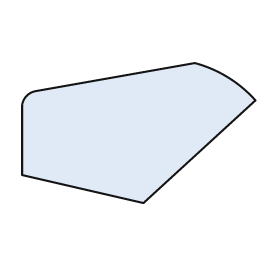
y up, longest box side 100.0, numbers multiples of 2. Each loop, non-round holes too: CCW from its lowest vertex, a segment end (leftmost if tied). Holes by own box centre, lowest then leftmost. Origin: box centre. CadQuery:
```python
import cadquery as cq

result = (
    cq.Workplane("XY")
    .moveTo(2.0, -30.0)
    .lineTo(50.0, 14.0)
    .threePointArc((38.0, 24.0), (24.0, 30.0))
    .lineTo(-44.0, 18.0)
    .threePointArc((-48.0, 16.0), (-50.0, 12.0))
    .lineTo(-50.0, -18.0)
    .close()
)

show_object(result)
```